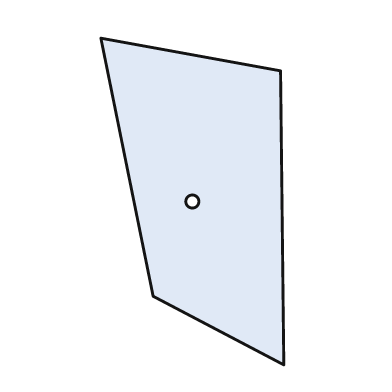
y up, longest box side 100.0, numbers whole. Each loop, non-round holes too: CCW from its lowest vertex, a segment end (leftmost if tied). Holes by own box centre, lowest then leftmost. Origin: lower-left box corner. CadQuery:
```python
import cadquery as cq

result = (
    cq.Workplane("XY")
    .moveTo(56.0, 0.0)
    .lineTo(55.0, 90.0)
    .lineTo(0.0, 100.0)
    .lineTo(16.0, 21.0)
    .close()
    .moveTo(28.0, 50.0)
    .circle(2.0)
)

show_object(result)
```